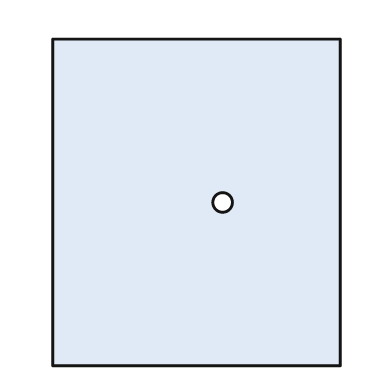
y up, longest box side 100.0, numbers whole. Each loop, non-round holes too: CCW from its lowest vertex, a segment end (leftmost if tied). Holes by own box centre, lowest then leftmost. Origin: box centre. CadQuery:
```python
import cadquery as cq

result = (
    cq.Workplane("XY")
    .moveTo(-44.0, -50.0)
    .lineTo(44.0, -50.0)
    .lineTo(44.0, 50.0)
    .lineTo(-44.0, 50.0)
    .close()
    .moveTo(8.0, 0.0)
    .circle(3.0)
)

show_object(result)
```